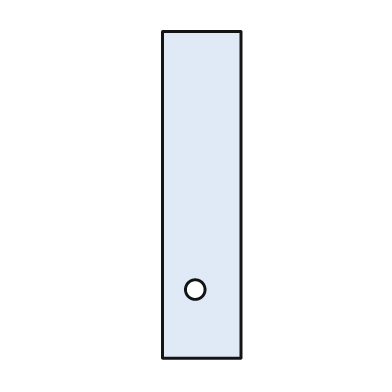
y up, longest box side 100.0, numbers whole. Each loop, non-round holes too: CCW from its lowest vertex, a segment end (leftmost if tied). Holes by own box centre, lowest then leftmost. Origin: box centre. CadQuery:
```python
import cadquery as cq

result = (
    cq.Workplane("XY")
    .moveTo(-12.0, -50.0)
    .lineTo(12.0, -50.0)
    .lineTo(12.0, 50.0)
    .lineTo(-12.0, 50.0)
    .close()
    .moveTo(-2.0, -29.0)
    .circle(3.0)
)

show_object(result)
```